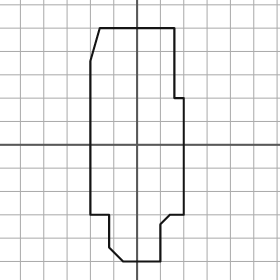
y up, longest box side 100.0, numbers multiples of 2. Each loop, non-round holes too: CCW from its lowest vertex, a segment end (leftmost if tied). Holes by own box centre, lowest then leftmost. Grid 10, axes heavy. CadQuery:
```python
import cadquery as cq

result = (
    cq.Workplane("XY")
    .moveTo(-6.0, -50.0)
    .lineTo(10.0, -50.0)
    .lineTo(10.0, -34.0)
    .lineTo(14.0, -30.0)
    .lineTo(20.0, -30.0)
    .lineTo(20.0, 20.0)
    .lineTo(16.0, 20.0)
    .lineTo(16.0, 50.0)
    .lineTo(-16.0, 50.0)
    .lineTo(-20.0, 36.0)
    .lineTo(-20.0, -30.0)
    .lineTo(-12.0, -30.0)
    .lineTo(-12.0, -44.0)
    .close()
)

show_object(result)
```